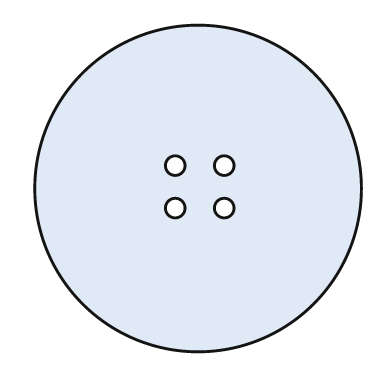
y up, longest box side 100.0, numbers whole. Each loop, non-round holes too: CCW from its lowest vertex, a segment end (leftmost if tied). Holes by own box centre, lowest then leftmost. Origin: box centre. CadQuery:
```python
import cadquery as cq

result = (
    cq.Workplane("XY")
    .moveTo(0.0, 0.0)
    .circle(50.0)
    .moveTo(-7.0, -6.0)
    .circle(3.0)
    .moveTo(8.0, -6.0)
    .circle(3.0)
    .moveTo(-7.0, 7.0)
    .circle(3.0)
    .moveTo(8.0, 7.0)
    .circle(3.0)
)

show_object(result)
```